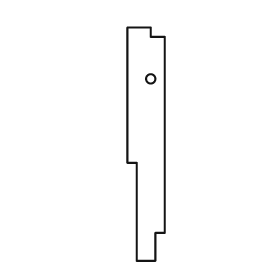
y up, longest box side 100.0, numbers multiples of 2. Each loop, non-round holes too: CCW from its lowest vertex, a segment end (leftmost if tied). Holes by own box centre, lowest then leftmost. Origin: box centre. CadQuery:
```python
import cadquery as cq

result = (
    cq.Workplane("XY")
    .moveTo(-4.0, -50.0)
    .lineTo(4.0, -50.0)
    .lineTo(4.0, -38.0)
    .lineTo(8.0, -38.0)
    .lineTo(8.0, 46.0)
    .lineTo(2.0, 46.0)
    .lineTo(2.0, 50.0)
    .lineTo(-8.0, 50.0)
    .lineTo(-8.0, -8.0)
    .lineTo(-4.0, -8.0)
    .close()
    .moveTo(2.0, 28.0)
    .circle(2.0)
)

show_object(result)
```